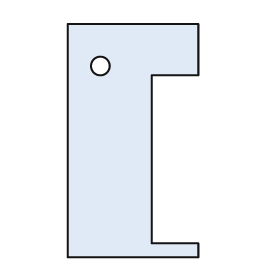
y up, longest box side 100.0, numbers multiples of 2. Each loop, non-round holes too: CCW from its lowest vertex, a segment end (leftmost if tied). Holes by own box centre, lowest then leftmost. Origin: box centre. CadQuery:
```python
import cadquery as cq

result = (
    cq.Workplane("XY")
    .moveTo(-28.0, -50.0)
    .lineTo(28.0, -50.0)
    .lineTo(28.0, -44.0)
    .lineTo(8.0, -44.0)
    .lineTo(8.0, 28.0)
    .lineTo(28.0, 28.0)
    .lineTo(28.0, 50.0)
    .lineTo(-28.0, 50.0)
    .close()
    .moveTo(-14.0, 32.0)
    .circle(4.0)
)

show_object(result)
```